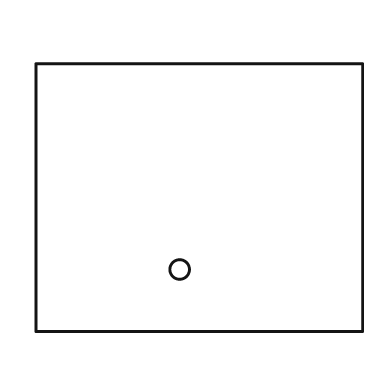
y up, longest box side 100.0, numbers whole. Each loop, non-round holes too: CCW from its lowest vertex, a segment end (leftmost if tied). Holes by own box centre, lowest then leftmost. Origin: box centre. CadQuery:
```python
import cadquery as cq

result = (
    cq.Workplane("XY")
    .moveTo(-50.0, -41.0)
    .lineTo(50.0, -41.0)
    .lineTo(50.0, 41.0)
    .lineTo(-50.0, 41.0)
    .close()
    .moveTo(-6.0, -22.0)
    .circle(3.0)
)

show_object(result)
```